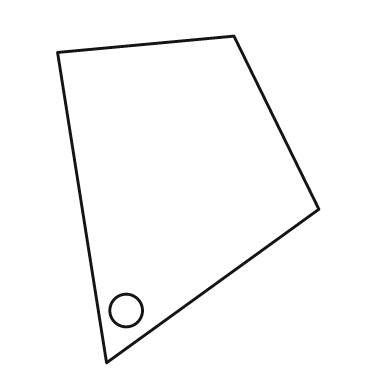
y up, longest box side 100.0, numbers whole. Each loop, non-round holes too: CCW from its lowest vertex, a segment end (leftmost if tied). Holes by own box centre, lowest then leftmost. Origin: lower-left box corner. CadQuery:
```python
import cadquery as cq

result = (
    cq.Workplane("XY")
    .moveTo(15.0, 0.0)
    .lineTo(80.0, 47.0)
    .lineTo(54.0, 100.0)
    .lineTo(0.0, 95.0)
    .close()
    .moveTo(21.0, 16.0)
    .circle(5.0)
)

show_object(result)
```